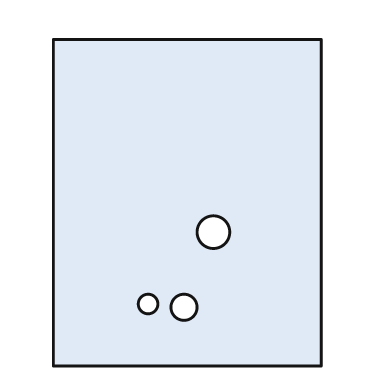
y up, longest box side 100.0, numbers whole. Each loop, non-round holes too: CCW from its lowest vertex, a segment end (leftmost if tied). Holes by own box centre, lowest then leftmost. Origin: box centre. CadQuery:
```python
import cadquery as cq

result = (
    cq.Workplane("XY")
    .moveTo(-41.0, -50.0)
    .lineTo(41.0, -50.0)
    .lineTo(41.0, 50.0)
    .lineTo(-41.0, 50.0)
    .close()
    .moveTo(-1.0, -32.0)
    .circle(4.0)
    .moveTo(-12.0, -31.0)
    .circle(3.0)
    .moveTo(8.0, -9.0)
    .circle(5.0)
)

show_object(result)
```